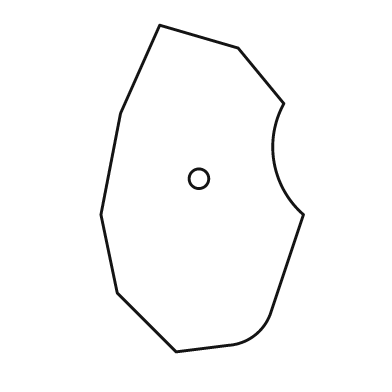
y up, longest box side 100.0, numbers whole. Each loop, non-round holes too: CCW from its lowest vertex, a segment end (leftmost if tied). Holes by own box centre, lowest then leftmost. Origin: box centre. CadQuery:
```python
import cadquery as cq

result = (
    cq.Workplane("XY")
    .moveTo(-8.0, -50.0)
    .lineTo(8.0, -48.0)
    .threePointArc((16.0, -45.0), (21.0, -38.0))
    .lineTo(31.0, -8.0)
    .threePointArc((22.0, 8.0), (25.0, 26.0))
    .lineTo(11.0, 43.0)
    .lineTo(-13.0, 50.0)
    .lineTo(-25.0, 23.0)
    .lineTo(-31.0, -8.0)
    .lineTo(-26.0, -32.0)
    .close()
    .moveTo(-1.0, 3.0)
    .circle(3.0)
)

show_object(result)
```